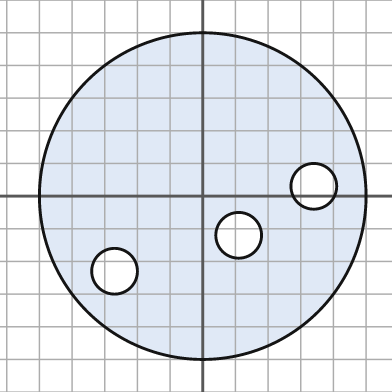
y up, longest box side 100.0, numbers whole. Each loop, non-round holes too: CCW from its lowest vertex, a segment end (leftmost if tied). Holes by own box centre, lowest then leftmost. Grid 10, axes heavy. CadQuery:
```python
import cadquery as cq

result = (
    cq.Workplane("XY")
    .moveTo(0.0, 0.0)
    .circle(50.0)
    .moveTo(-27.0, -23.0)
    .circle(7.0)
    .moveTo(11.0, -12.0)
    .circle(7.0)
    .moveTo(34.0, 3.0)
    .circle(7.0)
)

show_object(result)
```